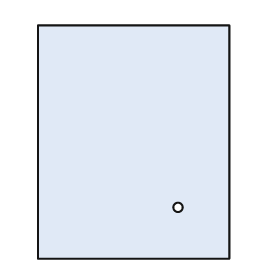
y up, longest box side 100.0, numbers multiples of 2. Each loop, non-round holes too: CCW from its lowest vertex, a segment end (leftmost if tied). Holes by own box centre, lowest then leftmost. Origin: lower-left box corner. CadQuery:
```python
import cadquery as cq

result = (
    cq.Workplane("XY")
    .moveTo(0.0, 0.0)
    .lineTo(82.0, 0.0)
    .lineTo(82.0, 100.0)
    .lineTo(0.0, 100.0)
    .close()
    .moveTo(60.0, 22.0)
    .circle(2.0)
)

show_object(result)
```